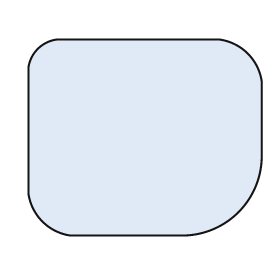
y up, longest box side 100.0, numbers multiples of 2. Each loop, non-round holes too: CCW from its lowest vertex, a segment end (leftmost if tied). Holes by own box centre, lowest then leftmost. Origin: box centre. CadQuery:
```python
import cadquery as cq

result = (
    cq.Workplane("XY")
    .moveTo(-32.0, -42.0)
    .lineTo(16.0, -42.0)
    .threePointArc((40.0, -32.0), (50.0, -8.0))
    .lineTo(50.0, 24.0)
    .threePointArc((44.0, 36.0), (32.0, 42.0))
    .lineTo(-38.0, 42.0)
    .threePointArc((-46.0, 38.0), (-50.0, 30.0))
    .lineTo(-50.0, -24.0)
    .threePointArc((-44.0, -36.0), (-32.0, -42.0))
    .close()
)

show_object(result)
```